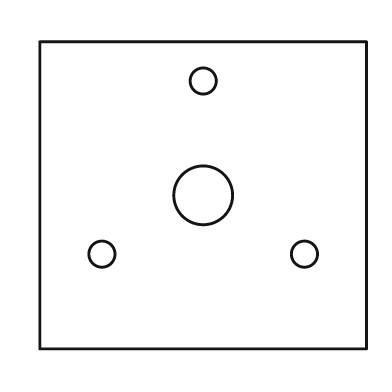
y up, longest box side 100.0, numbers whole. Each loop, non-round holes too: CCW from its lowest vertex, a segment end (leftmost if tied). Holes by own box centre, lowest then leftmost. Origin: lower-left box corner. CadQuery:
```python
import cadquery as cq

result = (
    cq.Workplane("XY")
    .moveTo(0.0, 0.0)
    .lineTo(100.0, 0.0)
    .lineTo(100.0, 94.0)
    .lineTo(0.0, 94.0)
    .close()
    .moveTo(19.0, 29.0)
    .circle(4.0)
    .moveTo(81.0, 29.0)
    .circle(4.0)
    .moveTo(50.0, 47.0)
    .circle(9.0)
    .moveTo(50.0, 82.0)
    .circle(4.0)
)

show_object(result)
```